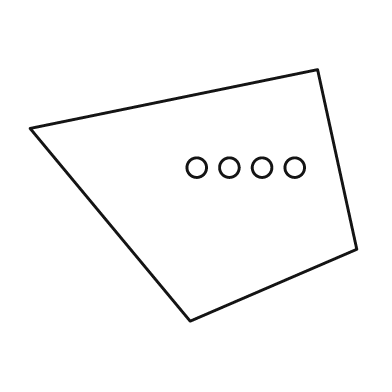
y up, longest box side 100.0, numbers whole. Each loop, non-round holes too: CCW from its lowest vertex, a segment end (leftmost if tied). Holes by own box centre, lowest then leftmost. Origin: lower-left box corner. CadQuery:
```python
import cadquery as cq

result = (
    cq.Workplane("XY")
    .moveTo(49.0, 0.0)
    .lineTo(100.0, 22.0)
    .lineTo(88.0, 77.0)
    .lineTo(0.0, 59.0)
    .close()
    .moveTo(51.0, 47.0)
    .circle(3.0)
    .moveTo(61.0, 47.0)
    .circle(3.0)
    .moveTo(71.0, 47.0)
    .circle(3.0)
    .moveTo(81.0, 47.0)
    .circle(3.0)
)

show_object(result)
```